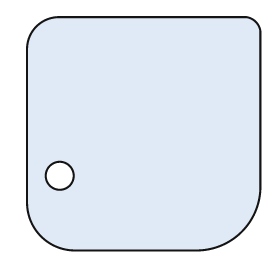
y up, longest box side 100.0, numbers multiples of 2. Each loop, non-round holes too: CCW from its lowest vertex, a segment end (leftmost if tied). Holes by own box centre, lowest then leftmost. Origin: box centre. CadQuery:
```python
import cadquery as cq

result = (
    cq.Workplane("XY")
    .moveTo(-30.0, -50.0)
    .lineTo(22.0, -50.0)
    .threePointArc((42.0, -42.0), (50.0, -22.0))
    .lineTo(50.0, 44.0)
    .threePointArc((48.0, 48.0), (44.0, 50.0))
    .lineTo(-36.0, 50.0)
    .threePointArc((-46.0, 46.0), (-50.0, 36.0))
    .lineTo(-50.0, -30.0)
    .threePointArc((-44.0, -44.0), (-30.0, -50.0))
    .close()
    .moveTo(-36.0, -18.0)
    .circle(6.0)
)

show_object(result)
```